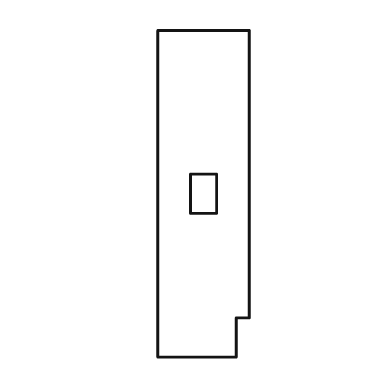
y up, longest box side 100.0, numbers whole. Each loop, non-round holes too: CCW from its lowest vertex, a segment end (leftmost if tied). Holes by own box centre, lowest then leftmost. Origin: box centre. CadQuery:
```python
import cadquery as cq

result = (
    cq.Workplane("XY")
    .moveTo(-14.0, -50.0)
    .lineTo(10.0, -50.0)
    .lineTo(10.0, -38.0)
    .lineTo(14.0, -38.0)
    .lineTo(14.0, 50.0)
    .lineTo(-14.0, 50.0)
    .close()
    .moveTo(-4.0, -6.0)
    .lineTo(4.0, -6.0)
    .lineTo(4.0, 6.0)
    .lineTo(-4.0, 6.0)
    .close()
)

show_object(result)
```